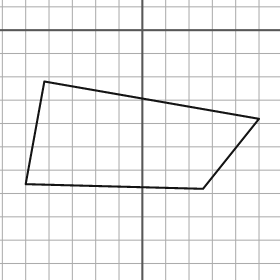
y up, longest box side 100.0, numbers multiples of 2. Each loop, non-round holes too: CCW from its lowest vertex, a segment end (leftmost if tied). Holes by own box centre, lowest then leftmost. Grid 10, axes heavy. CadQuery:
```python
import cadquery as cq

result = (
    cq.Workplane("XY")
    .moveTo(26.0, -68.0)
    .lineTo(50.0, -38.0)
    .lineTo(-42.0, -22.0)
    .lineTo(-50.0, -66.0)
    .close()
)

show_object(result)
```